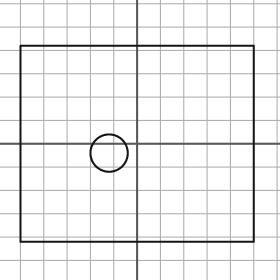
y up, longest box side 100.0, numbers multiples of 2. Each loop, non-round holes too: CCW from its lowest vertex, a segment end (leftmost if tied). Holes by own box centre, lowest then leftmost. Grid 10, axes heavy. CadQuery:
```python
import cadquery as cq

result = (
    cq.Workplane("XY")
    .moveTo(-50.0, -42.0)
    .lineTo(50.0, -42.0)
    .lineTo(50.0, 42.0)
    .lineTo(-50.0, 42.0)
    .close()
    .moveTo(-12.0, -4.0)
    .circle(8.0)
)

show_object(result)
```